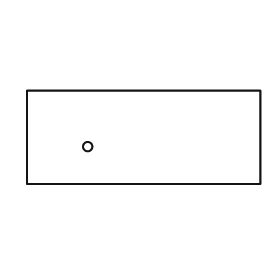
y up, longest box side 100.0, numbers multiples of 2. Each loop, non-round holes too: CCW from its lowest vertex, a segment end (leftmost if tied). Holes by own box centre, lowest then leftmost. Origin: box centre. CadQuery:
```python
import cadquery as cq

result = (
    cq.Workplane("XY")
    .moveTo(-50.0, -20.0)
    .lineTo(50.0, -20.0)
    .lineTo(50.0, 20.0)
    .lineTo(-50.0, 20.0)
    .close()
    .moveTo(-24.0, -4.0)
    .circle(2.0)
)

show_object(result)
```